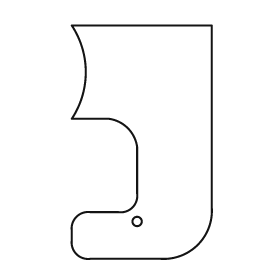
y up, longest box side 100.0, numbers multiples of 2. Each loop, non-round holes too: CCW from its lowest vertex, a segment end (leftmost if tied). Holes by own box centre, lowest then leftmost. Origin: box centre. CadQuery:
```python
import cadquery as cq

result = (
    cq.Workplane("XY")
    .moveTo(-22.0, -50.0)
    .lineTo(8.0, -50.0)
    .threePointArc((24.0, -44.0), (30.0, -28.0))
    .lineTo(30.0, 50.0)
    .lineTo(-30.0, 50.0)
    .threePointArc((-24.0, 30.0), (-30.0, 10.0))
    .lineTo(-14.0, 10.0)
    .threePointArc((-6.0, 6.0), (-2.0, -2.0))
    .lineTo(-2.0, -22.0)
    .threePointArc((-4.0, -28.0), (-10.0, -30.0))
    .lineTo(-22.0, -30.0)
    .threePointArc((-28.0, -32.0), (-30.0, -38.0))
    .lineTo(-30.0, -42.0)
    .threePointArc((-28.0, -48.0), (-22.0, -50.0))
    .close()
    .moveTo(-2.0, -34.0)
    .circle(2.0)
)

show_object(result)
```